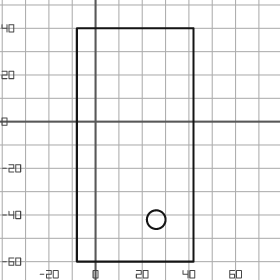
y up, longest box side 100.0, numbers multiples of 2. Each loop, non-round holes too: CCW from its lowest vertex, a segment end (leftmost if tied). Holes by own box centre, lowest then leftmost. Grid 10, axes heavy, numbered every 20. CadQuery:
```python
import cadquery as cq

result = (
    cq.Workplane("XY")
    .moveTo(-8.0, -60.0)
    .lineTo(42.0, -60.0)
    .lineTo(42.0, 40.0)
    .lineTo(-8.0, 40.0)
    .close()
    .moveTo(26.0, -42.0)
    .circle(4.0)
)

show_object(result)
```